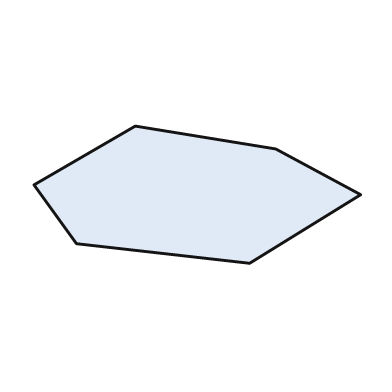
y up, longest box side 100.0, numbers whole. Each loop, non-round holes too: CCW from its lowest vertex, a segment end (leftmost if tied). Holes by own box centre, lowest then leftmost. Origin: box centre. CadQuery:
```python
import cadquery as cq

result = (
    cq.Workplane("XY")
    .moveTo(16.0, -21.0)
    .lineTo(50.0, 0.0)
    .lineTo(24.0, 14.0)
    .lineTo(-19.0, 21.0)
    .lineTo(-50.0, 3.0)
    .lineTo(-37.0, -15.0)
    .close()
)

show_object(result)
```